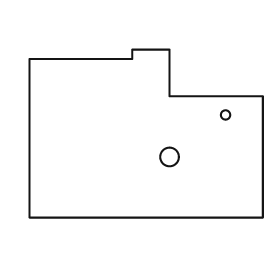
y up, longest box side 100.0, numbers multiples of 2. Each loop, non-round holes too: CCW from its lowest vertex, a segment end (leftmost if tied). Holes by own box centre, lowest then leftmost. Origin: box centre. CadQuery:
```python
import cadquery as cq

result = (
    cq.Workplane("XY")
    .moveTo(-50.0, -36.0)
    .lineTo(50.0, -36.0)
    .lineTo(50.0, 16.0)
    .lineTo(10.0, 16.0)
    .lineTo(10.0, 36.0)
    .lineTo(-6.0, 36.0)
    .lineTo(-6.0, 32.0)
    .lineTo(-50.0, 32.0)
    .close()
    .moveTo(10.0, -10.0)
    .circle(4.0)
    .moveTo(34.0, 8.0)
    .circle(2.0)
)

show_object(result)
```